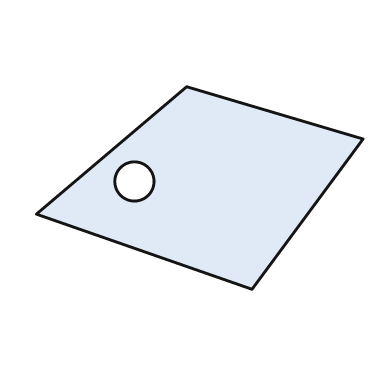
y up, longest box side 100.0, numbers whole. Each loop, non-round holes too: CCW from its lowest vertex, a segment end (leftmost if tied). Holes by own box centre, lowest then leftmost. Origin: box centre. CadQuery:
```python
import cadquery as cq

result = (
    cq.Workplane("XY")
    .moveTo(16.0, -31.0)
    .lineTo(50.0, 15.0)
    .lineTo(-4.0, 31.0)
    .lineTo(-50.0, -8.0)
    .close()
    .moveTo(-20.0, 2.0)
    .circle(6.0)
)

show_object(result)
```